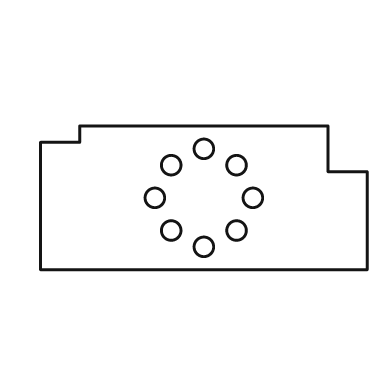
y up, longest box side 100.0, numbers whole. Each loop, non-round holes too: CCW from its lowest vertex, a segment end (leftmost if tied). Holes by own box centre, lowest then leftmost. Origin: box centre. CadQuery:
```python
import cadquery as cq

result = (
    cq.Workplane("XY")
    .moveTo(-50.0, -22.0)
    .lineTo(50.0, -22.0)
    .lineTo(50.0, 8.0)
    .lineTo(38.0, 8.0)
    .lineTo(38.0, 22.0)
    .lineTo(-38.0, 22.0)
    .lineTo(-38.0, 17.0)
    .lineTo(-50.0, 17.0)
    .close()
    .moveTo(0.0, -15.0)
    .circle(3.0)
    .moveTo(-10.0, -10.0)
    .circle(3.0)
    .moveTo(10.0, -10.0)
    .circle(3.0)
    .moveTo(-15.0, 0.0)
    .circle(3.0)
    .moveTo(15.0, 0.0)
    .circle(3.0)
    .moveTo(-10.0, 10.0)
    .circle(3.0)
    .moveTo(10.0, 10.0)
    .circle(3.0)
    .moveTo(0.0, 15.0)
    .circle(3.0)
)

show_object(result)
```